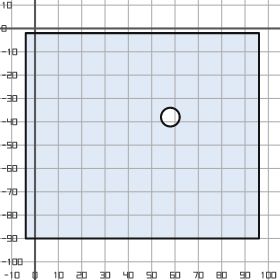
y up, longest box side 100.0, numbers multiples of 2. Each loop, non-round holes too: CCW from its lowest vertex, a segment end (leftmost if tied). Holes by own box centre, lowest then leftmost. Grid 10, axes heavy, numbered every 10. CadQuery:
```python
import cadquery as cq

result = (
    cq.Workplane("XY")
    .moveTo(-4.0, -90.0)
    .lineTo(96.0, -90.0)
    .lineTo(96.0, -2.0)
    .lineTo(-4.0, -2.0)
    .close()
    .moveTo(58.0, -38.0)
    .circle(4.0)
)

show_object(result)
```